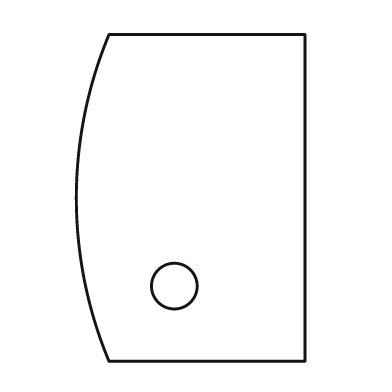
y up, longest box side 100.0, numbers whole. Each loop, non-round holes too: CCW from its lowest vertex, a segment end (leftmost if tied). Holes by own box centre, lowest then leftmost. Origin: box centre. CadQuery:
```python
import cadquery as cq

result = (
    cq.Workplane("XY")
    .moveTo(-25.0, -50.0)
    .lineTo(35.0, -50.0)
    .lineTo(35.0, 50.0)
    .lineTo(-25.0, 50.0)
    .threePointArc((-35.0, 0.0), (-25.0, -50.0))
    .close()
    .moveTo(-5.0, -27.0)
    .circle(7.0)
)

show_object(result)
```